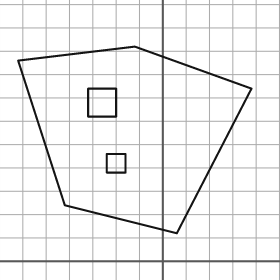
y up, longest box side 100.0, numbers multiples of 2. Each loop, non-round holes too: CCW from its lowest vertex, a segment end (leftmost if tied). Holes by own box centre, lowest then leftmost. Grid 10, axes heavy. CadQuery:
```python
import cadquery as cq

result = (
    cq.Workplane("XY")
    .moveTo(6.0, 12.0)
    .lineTo(38.0, 74.0)
    .lineTo(-12.0, 92.0)
    .lineTo(-62.0, 86.0)
    .lineTo(-42.0, 24.0)
    .close()
    .moveTo(-24.0, 38.0)
    .lineTo(-16.0, 38.0)
    .lineTo(-16.0, 46.0)
    .lineTo(-24.0, 46.0)
    .close()
    .moveTo(-32.0, 62.0)
    .lineTo(-20.0, 62.0)
    .lineTo(-20.0, 74.0)
    .lineTo(-32.0, 74.0)
    .close()
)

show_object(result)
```